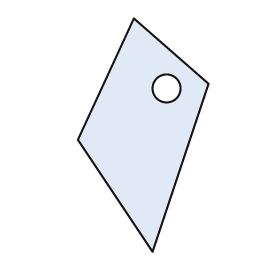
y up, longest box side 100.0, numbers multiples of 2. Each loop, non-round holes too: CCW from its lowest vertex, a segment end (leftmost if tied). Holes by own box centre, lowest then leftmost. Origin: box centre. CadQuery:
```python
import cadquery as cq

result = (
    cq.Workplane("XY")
    .moveTo(4.0, -50.0)
    .lineTo(28.0, 22.0)
    .lineTo(-4.0, 50.0)
    .lineTo(-28.0, -2.0)
    .close()
    .moveTo(10.0, 20.0)
    .circle(6.0)
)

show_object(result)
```